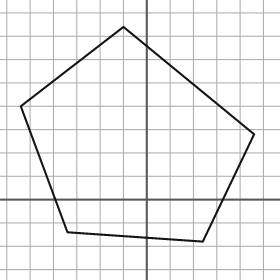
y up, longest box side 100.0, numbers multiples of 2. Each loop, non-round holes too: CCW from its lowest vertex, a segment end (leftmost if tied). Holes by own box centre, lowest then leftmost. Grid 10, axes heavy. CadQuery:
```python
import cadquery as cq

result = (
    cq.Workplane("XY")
    .moveTo(24.0, -18.0)
    .lineTo(46.0, 28.0)
    .lineTo(-10.0, 74.0)
    .lineTo(-54.0, 40.0)
    .lineTo(-34.0, -14.0)
    .close()
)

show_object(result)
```